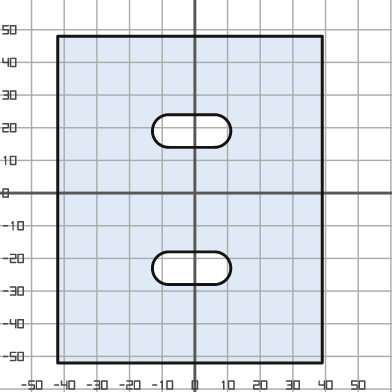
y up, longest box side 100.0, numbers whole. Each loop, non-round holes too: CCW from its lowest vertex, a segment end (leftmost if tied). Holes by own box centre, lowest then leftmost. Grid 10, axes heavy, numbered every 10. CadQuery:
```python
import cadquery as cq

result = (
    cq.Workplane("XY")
    .moveTo(-42.0, -52.0)
    .lineTo(39.0, -52.0)
    .lineTo(39.0, 48.0)
    .lineTo(-42.0, 48.0)
    .close()
    .moveTo(-8.0, -28.0)
    .lineTo(6.0, -28.0)
    .threePointArc((11.0, -23.0), (6.0, -18.0))
    .lineTo(-8.0, -18.0)
    .threePointArc((-13.0, -23.0), (-8.0, -28.0))
    .close()
    .moveTo(-8.0, 14.0)
    .lineTo(6.0, 14.0)
    .threePointArc((11.0, 19.0), (6.0, 24.0))
    .lineTo(-8.0, 24.0)
    .threePointArc((-13.0, 19.0), (-8.0, 14.0))
    .close()
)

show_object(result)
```